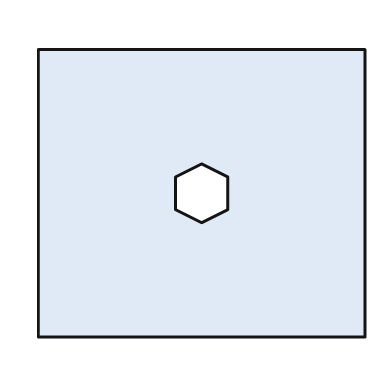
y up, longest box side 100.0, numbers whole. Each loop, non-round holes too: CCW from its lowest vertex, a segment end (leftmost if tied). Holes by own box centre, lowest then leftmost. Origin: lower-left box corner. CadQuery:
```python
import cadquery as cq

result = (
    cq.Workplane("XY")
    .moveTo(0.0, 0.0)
    .lineTo(100.0, 0.0)
    .lineTo(100.0, 88.0)
    .lineTo(0.0, 88.0)
    .close()
    .moveTo(50.0, 35.0)
    .lineTo(58.0, 39.0)
    .lineTo(58.0, 49.0)
    .lineTo(50.0, 53.0)
    .lineTo(42.0, 49.0)
    .lineTo(42.0, 39.0)
    .close()
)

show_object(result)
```